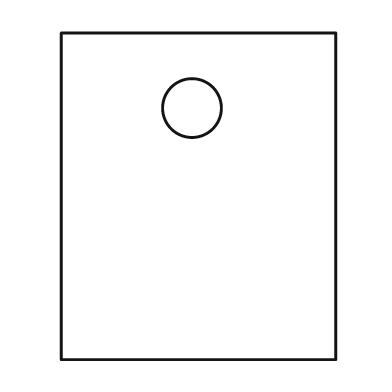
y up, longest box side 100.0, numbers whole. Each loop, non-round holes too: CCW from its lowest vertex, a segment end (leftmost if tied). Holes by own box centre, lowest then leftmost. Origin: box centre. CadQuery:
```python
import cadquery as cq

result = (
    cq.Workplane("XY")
    .moveTo(-42.0, -50.0)
    .lineTo(42.0, -50.0)
    .lineTo(42.0, 50.0)
    .lineTo(-42.0, 50.0)
    .close()
    .moveTo(-2.0, 27.0)
    .circle(9.0)
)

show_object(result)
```